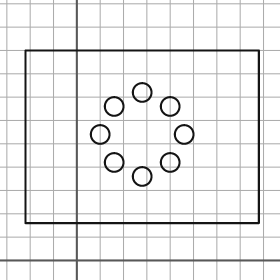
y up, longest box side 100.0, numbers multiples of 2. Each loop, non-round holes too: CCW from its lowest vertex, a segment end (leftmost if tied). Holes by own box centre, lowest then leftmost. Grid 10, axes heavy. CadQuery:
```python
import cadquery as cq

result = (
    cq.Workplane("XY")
    .moveTo(-22.0, 16.0)
    .lineTo(78.0, 16.0)
    .lineTo(78.0, 90.0)
    .lineTo(-22.0, 90.0)
    .close()
    .moveTo(28.0, 36.0)
    .circle(4.0)
    .moveTo(16.0, 42.0)
    .circle(4.0)
    .moveTo(40.0, 42.0)
    .circle(4.0)
    .moveTo(10.0, 54.0)
    .circle(4.0)
    .moveTo(46.0, 54.0)
    .circle(4.0)
    .moveTo(16.0, 66.0)
    .circle(4.0)
    .moveTo(40.0, 66.0)
    .circle(4.0)
    .moveTo(28.0, 72.0)
    .circle(4.0)
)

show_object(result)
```